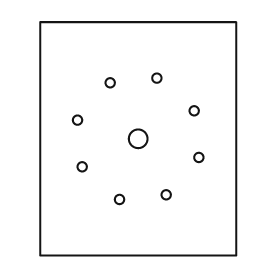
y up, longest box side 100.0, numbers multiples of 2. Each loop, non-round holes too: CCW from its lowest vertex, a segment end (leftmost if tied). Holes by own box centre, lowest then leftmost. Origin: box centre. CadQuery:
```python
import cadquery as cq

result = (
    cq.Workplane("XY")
    .moveTo(-42.0, -50.0)
    .lineTo(42.0, -50.0)
    .lineTo(42.0, 50.0)
    .lineTo(-42.0, 50.0)
    .close()
    .moveTo(-8.0, -26.0)
    .circle(2.0)
    .moveTo(12.0, -24.0)
    .circle(2.0)
    .moveTo(-24.0, -12.0)
    .circle(2.0)
    .moveTo(26.0, -8.0)
    .circle(2.0)
    .moveTo(0.0, 0.0)
    .circle(4.0)
    .moveTo(-26.0, 8.0)
    .circle(2.0)
    .moveTo(24.0, 12.0)
    .circle(2.0)
    .moveTo(-12.0, 24.0)
    .circle(2.0)
    .moveTo(8.0, 26.0)
    .circle(2.0)
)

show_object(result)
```